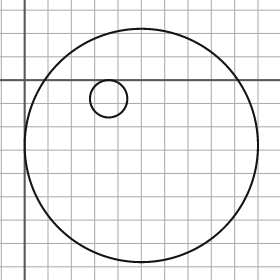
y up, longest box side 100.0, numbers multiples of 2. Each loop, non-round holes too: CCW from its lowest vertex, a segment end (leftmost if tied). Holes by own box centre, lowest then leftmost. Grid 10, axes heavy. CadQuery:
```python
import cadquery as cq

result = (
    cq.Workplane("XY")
    .moveTo(50.0, -28.0)
    .circle(50.0)
    .moveTo(36.0, -8.0)
    .circle(8.0)
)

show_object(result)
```